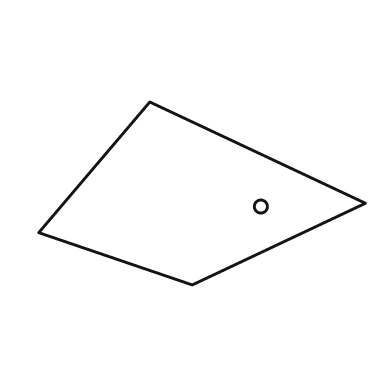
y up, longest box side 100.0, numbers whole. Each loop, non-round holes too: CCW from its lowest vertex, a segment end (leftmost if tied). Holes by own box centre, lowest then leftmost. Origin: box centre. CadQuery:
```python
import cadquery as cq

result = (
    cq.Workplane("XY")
    .moveTo(-3.0, -28.0)
    .lineTo(50.0, -3.0)
    .lineTo(-16.0, 28.0)
    .lineTo(-50.0, -12.0)
    .close()
    .moveTo(18.0, -4.0)
    .circle(2.0)
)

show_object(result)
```